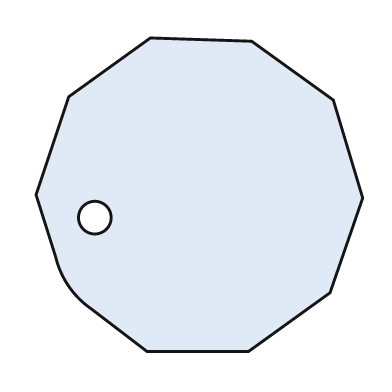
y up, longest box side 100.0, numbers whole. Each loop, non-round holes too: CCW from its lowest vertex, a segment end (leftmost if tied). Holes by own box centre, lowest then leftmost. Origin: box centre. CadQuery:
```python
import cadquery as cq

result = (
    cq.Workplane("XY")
    .moveTo(-16.0, -48.0)
    .lineTo(15.0, -48.0)
    .lineTo(40.0, -30.0)
    .lineTo(50.0, -1.0)
    .lineTo(41.0, 29.0)
    .lineTo(16.0, 47.0)
    .lineTo(-15.0, 48.0)
    .lineTo(-40.0, 30.0)
    .lineTo(-50.0, 0.0)
    .lineTo(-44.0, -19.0)
    .threePointArc((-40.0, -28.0), (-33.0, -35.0))
    .close()
    .moveTo(-32.0, -7.0)
    .circle(5.0)
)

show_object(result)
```